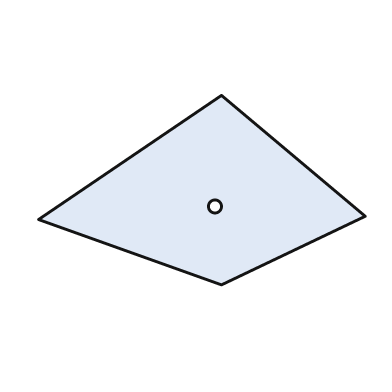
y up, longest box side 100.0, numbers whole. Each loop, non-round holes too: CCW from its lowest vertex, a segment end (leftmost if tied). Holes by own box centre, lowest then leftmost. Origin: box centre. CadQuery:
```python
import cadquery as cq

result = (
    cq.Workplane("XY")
    .moveTo(6.0, -29.0)
    .lineTo(50.0, -8.0)
    .lineTo(6.0, 29.0)
    .lineTo(-50.0, -9.0)
    .close()
    .moveTo(4.0, -5.0)
    .circle(2.0)
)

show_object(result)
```